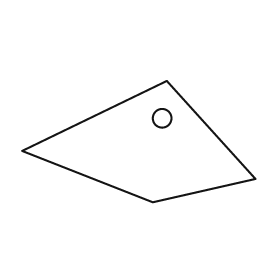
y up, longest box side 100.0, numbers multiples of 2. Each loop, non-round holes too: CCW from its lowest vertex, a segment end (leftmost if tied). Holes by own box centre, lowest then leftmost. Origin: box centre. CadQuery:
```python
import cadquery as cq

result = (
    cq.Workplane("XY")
    .moveTo(6.0, -26.0)
    .lineTo(50.0, -16.0)
    .lineTo(12.0, 26.0)
    .lineTo(-50.0, -4.0)
    .close()
    .moveTo(10.0, 10.0)
    .circle(4.0)
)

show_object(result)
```